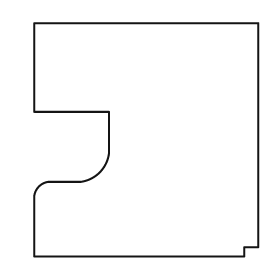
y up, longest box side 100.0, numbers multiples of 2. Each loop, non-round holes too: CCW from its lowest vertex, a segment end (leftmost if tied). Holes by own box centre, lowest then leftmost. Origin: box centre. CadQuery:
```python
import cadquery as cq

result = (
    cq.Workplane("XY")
    .moveTo(-48.0, -50.0)
    .lineTo(42.0, -50.0)
    .lineTo(42.0, -46.0)
    .lineTo(48.0, -46.0)
    .lineTo(48.0, 50.0)
    .lineTo(-48.0, 50.0)
    .lineTo(-48.0, 12.0)
    .lineTo(-16.0, 12.0)
    .lineTo(-16.0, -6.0)
    .threePointArc((-20.0, -14.0), (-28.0, -18.0))
    .lineTo(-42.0, -18.0)
    .threePointArc((-46.0, -20.0), (-48.0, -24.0))
    .close()
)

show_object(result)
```